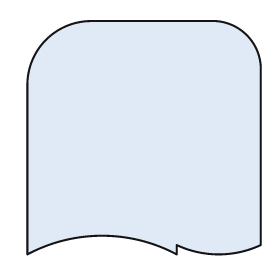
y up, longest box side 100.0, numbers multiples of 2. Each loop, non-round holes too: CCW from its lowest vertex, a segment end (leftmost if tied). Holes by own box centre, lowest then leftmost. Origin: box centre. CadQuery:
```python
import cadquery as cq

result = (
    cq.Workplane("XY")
    .moveTo(-50.0, -50.0)
    .threePointArc((-18.0, -42.0), (14.0, -50.0))
    .lineTo(14.0, -46.0)
    .threePointArc((32.0, -50.0), (50.0, -46.0))
    .lineTo(50.0, 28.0)
    .threePointArc((44.0, 44.0), (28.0, 50.0))
    .lineTo(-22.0, 50.0)
    .threePointArc((-42.0, 42.0), (-50.0, 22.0))
    .close()
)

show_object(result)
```